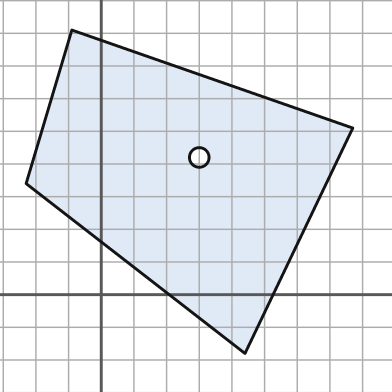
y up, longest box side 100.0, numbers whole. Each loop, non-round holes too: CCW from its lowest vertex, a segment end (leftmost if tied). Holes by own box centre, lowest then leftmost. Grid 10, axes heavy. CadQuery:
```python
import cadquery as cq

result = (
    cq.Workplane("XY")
    .moveTo(44.0, -18.0)
    .lineTo(77.0, 51.0)
    .lineTo(-9.0, 81.0)
    .lineTo(-23.0, 34.0)
    .close()
    .moveTo(30.0, 42.0)
    .circle(3.0)
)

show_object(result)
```